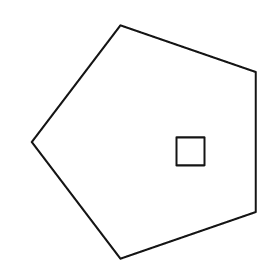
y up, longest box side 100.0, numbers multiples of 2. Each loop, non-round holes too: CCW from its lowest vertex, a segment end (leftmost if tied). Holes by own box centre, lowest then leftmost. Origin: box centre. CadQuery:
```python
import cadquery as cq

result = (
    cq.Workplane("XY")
    .moveTo(-10.0, -50.0)
    .lineTo(48.0, -30.0)
    .lineTo(48.0, 30.0)
    .lineTo(-10.0, 50.0)
    .lineTo(-48.0, 0.0)
    .close()
    .moveTo(14.0, -10.0)
    .lineTo(26.0, -10.0)
    .lineTo(26.0, 2.0)
    .lineTo(14.0, 2.0)
    .close()
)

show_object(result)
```